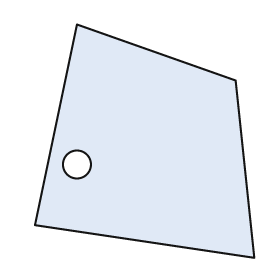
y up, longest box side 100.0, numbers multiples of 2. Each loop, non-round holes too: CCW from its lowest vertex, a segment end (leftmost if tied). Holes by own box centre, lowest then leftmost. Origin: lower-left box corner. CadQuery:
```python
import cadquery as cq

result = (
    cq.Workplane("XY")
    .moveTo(94.0, 0.0)
    .lineTo(86.0, 76.0)
    .lineTo(18.0, 100.0)
    .lineTo(0.0, 14.0)
    .close()
    .moveTo(18.0, 40.0)
    .circle(6.0)
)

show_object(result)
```